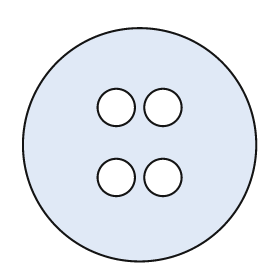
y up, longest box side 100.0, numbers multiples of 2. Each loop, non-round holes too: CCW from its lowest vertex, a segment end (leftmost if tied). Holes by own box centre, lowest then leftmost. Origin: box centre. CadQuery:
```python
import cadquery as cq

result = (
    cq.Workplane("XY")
    .moveTo(0.0, 0.0)
    .circle(50.0)
    .moveTo(-10.0, -14.0)
    .circle(8.0)
    .moveTo(10.0, -14.0)
    .circle(8.0)
    .moveTo(-10.0, 16.0)
    .circle(8.0)
    .moveTo(10.0, 16.0)
    .circle(8.0)
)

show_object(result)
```